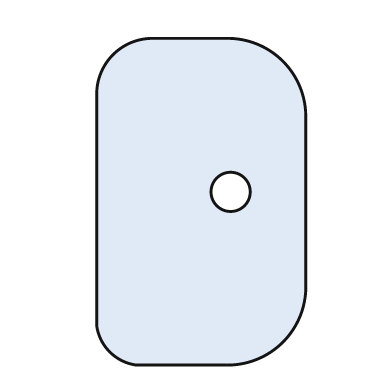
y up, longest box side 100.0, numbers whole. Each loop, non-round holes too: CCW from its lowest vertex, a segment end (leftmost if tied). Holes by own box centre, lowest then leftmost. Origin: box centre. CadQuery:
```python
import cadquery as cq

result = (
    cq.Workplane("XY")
    .moveTo(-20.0, -50.0)
    .lineTo(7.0, -50.0)
    .threePointArc((25.0, -43.0), (32.0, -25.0))
    .lineTo(32.0, 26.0)
    .threePointArc((25.0, 43.0), (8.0, 50.0))
    .lineTo(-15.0, 50.0)
    .threePointArc((-27.0, 45.0), (-32.0, 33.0))
    .lineTo(-32.0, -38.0)
    .threePointArc((-28.0, -46.0), (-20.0, -50.0))
    .close()
    .moveTo(9.0, 3.0)
    .circle(6.0)
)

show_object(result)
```